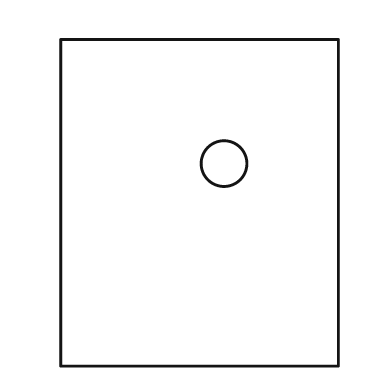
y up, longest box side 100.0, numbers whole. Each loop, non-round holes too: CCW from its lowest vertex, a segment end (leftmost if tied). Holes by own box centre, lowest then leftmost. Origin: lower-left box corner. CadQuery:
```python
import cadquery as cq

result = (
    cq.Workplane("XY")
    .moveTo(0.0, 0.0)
    .lineTo(85.0, 0.0)
    .lineTo(85.0, 100.0)
    .lineTo(0.0, 100.0)
    .close()
    .moveTo(50.0, 62.0)
    .circle(7.0)
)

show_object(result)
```